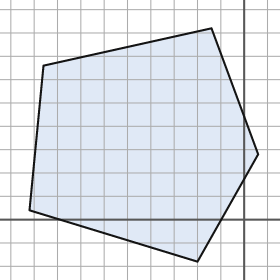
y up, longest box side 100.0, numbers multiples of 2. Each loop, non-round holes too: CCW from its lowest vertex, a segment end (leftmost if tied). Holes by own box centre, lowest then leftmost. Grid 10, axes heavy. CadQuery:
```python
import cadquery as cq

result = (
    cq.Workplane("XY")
    .moveTo(-20.0, -18.0)
    .lineTo(6.0, 28.0)
    .lineTo(-14.0, 82.0)
    .lineTo(-86.0, 66.0)
    .lineTo(-92.0, 4.0)
    .close()
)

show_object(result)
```